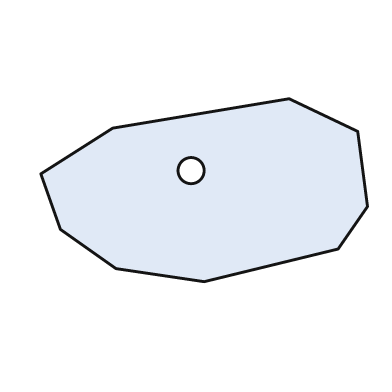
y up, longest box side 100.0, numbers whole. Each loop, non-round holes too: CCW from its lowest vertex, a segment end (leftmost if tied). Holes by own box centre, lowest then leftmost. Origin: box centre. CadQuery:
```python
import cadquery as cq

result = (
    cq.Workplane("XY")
    .moveTo(0.0, -28.0)
    .lineTo(41.0, -18.0)
    .lineTo(50.0, -5.0)
    .lineTo(47.0, 18.0)
    .lineTo(26.0, 28.0)
    .lineTo(-28.0, 19.0)
    .lineTo(-50.0, 5.0)
    .lineTo(-44.0, -12.0)
    .lineTo(-27.0, -24.0)
    .close()
    .moveTo(-4.0, 6.0)
    .circle(4.0)
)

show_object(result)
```